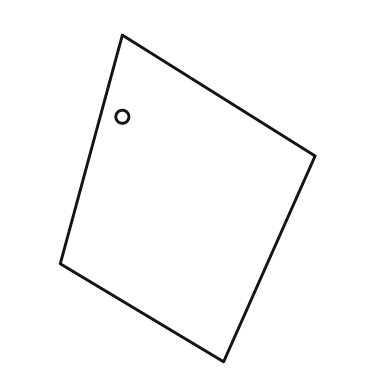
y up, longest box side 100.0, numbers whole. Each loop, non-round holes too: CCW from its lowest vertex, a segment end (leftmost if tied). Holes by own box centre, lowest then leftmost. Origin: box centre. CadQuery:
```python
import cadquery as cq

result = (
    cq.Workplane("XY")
    .moveTo(11.0, -50.0)
    .lineTo(39.0, 13.0)
    .lineTo(-20.0, 50.0)
    .lineTo(-39.0, -20.0)
    .close()
    .moveTo(-20.0, 25.0)
    .circle(2.0)
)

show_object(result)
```